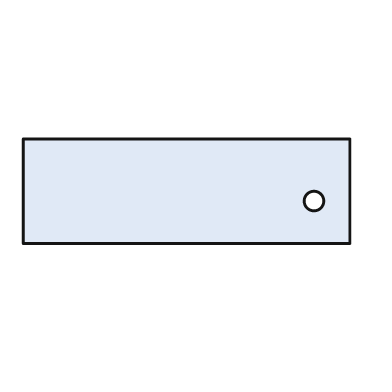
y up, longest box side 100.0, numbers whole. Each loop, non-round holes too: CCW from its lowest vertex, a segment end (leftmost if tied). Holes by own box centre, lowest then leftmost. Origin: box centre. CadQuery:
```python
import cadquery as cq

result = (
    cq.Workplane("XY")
    .moveTo(-50.0, -16.0)
    .lineTo(50.0, -16.0)
    .lineTo(50.0, 16.0)
    .lineTo(-50.0, 16.0)
    .close()
    .moveTo(39.0, -3.0)
    .circle(3.0)
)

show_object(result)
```